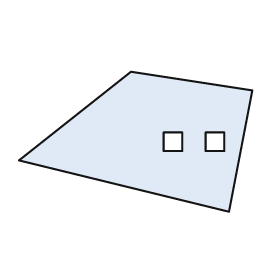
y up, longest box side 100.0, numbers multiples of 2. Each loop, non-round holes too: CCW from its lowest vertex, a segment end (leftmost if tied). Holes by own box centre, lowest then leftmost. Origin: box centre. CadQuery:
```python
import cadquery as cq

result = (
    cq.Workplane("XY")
    .moveTo(40.0, -30.0)
    .lineTo(50.0, 22.0)
    .lineTo(-2.0, 30.0)
    .lineTo(-50.0, -8.0)
    .close()
    .moveTo(12.0, -4.0)
    .lineTo(20.0, -4.0)
    .lineTo(20.0, 4.0)
    .lineTo(12.0, 4.0)
    .close()
    .moveTo(30.0, -4.0)
    .lineTo(38.0, -4.0)
    .lineTo(38.0, 4.0)
    .lineTo(30.0, 4.0)
    .close()
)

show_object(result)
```